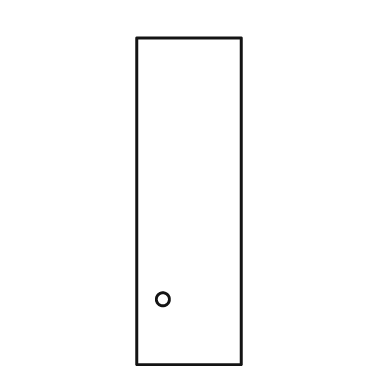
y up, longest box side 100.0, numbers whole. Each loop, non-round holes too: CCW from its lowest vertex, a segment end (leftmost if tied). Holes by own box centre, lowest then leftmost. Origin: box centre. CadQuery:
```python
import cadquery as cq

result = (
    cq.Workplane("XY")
    .moveTo(-16.0, -50.0)
    .lineTo(16.0, -50.0)
    .lineTo(16.0, 50.0)
    .lineTo(-16.0, 50.0)
    .close()
    .moveTo(-8.0, -30.0)
    .circle(2.0)
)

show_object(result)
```